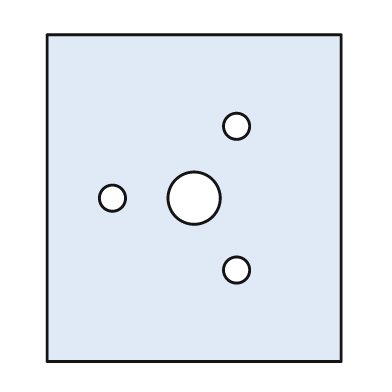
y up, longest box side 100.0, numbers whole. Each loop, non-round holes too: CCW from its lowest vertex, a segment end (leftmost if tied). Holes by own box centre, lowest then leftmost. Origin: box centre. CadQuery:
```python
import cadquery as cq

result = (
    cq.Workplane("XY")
    .moveTo(-45.0, -50.0)
    .lineTo(45.0, -50.0)
    .lineTo(45.0, 50.0)
    .lineTo(-45.0, 50.0)
    .close()
    .moveTo(13.0, -22.0)
    .circle(4.0)
    .moveTo(-25.0, 0.0)
    .circle(4.0)
    .moveTo(0.0, 0.0)
    .circle(8.0)
    .moveTo(13.0, 22.0)
    .circle(4.0)
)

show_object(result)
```